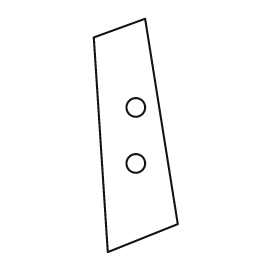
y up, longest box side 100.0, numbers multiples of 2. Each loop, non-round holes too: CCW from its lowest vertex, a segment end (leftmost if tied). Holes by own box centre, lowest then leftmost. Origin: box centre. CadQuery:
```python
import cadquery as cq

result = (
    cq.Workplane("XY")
    .moveTo(-12.0, -50.0)
    .lineTo(18.0, -38.0)
    .lineTo(4.0, 50.0)
    .lineTo(-18.0, 42.0)
    .close()
    .moveTo(0.0, -12.0)
    .circle(4.0)
    .moveTo(0.0, 12.0)
    .circle(4.0)
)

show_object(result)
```